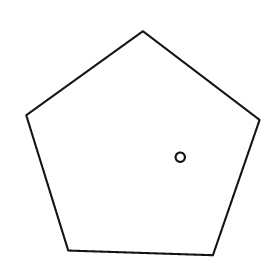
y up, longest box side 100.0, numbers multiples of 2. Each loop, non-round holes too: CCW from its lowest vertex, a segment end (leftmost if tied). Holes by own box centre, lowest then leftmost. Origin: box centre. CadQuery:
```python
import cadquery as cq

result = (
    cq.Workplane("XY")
    .moveTo(30.0, -48.0)
    .lineTo(50.0, 10.0)
    .lineTo(0.0, 48.0)
    .lineTo(-50.0, 12.0)
    .lineTo(-32.0, -46.0)
    .close()
    .moveTo(16.0, -6.0)
    .circle(2.0)
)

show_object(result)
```